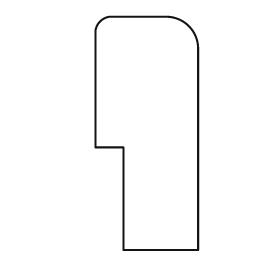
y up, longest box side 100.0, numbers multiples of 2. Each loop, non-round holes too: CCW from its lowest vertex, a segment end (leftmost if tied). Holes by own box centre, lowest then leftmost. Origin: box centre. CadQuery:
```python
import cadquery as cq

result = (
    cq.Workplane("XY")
    .moveTo(-10.0, -50.0)
    .lineTo(22.0, -50.0)
    .lineTo(22.0, 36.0)
    .threePointArc((18.0, 46.0), (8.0, 50.0))
    .lineTo(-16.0, 50.0)
    .threePointArc((-20.0, 48.0), (-22.0, 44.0))
    .lineTo(-22.0, -6.0)
    .lineTo(-10.0, -6.0)
    .close()
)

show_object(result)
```